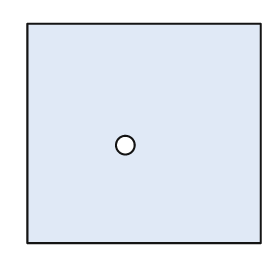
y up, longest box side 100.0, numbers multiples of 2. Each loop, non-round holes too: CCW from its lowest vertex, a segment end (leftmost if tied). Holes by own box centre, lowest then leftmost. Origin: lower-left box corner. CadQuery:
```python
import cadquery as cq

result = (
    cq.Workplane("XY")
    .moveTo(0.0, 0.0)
    .lineTo(100.0, 0.0)
    .lineTo(100.0, 94.0)
    .lineTo(0.0, 94.0)
    .close()
    .moveTo(42.0, 42.0)
    .circle(4.0)
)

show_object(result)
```